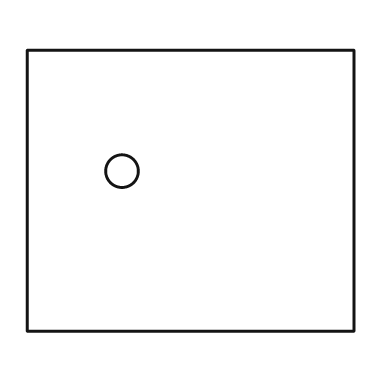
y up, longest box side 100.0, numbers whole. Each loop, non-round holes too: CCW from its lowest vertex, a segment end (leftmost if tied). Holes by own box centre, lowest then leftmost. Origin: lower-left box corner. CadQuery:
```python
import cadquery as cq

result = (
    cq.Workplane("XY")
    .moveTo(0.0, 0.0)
    .lineTo(100.0, 0.0)
    .lineTo(100.0, 86.0)
    .lineTo(0.0, 86.0)
    .close()
    .moveTo(29.0, 49.0)
    .circle(5.0)
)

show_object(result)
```